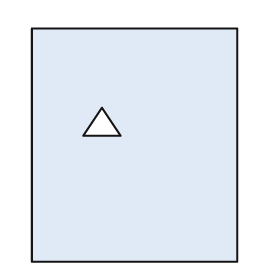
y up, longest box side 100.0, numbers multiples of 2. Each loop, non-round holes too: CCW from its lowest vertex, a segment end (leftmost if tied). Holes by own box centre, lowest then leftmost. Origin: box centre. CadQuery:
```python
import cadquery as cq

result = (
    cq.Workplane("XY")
    .moveTo(-44.0, -50.0)
    .lineTo(44.0, -50.0)
    .lineTo(44.0, 50.0)
    .lineTo(-44.0, 50.0)
    .close()
    .moveTo(-22.0, 4.0)
    .lineTo(-6.0, 4.0)
    .lineTo(-14.0, 16.0)
    .close()
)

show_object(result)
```